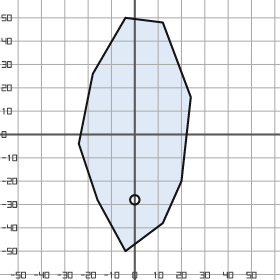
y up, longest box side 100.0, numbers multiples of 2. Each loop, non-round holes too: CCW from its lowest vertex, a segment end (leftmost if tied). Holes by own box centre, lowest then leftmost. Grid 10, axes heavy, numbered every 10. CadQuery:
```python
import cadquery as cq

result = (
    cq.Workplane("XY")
    .moveTo(-4.0, -50.0)
    .lineTo(12.0, -38.0)
    .lineTo(20.0, -20.0)
    .lineTo(24.0, 16.0)
    .lineTo(12.0, 48.0)
    .lineTo(-4.0, 50.0)
    .lineTo(-18.0, 26.0)
    .lineTo(-24.0, -4.0)
    .lineTo(-16.0, -28.0)
    .close()
    .moveTo(0.0, -28.0)
    .circle(2.0)
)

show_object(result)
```